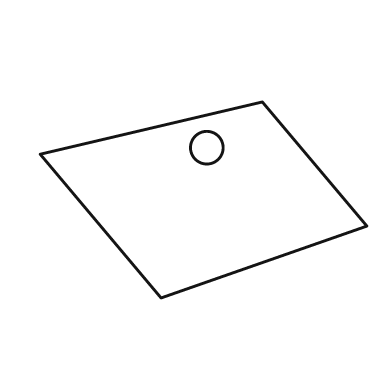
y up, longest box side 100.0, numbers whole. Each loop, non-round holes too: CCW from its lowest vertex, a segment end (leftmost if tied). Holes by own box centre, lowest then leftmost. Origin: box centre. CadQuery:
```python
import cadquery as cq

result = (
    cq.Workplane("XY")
    .moveTo(-13.0, -30.0)
    .lineTo(50.0, -8.0)
    .lineTo(18.0, 30.0)
    .lineTo(-50.0, 14.0)
    .close()
    .moveTo(1.0, 16.0)
    .circle(5.0)
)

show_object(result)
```